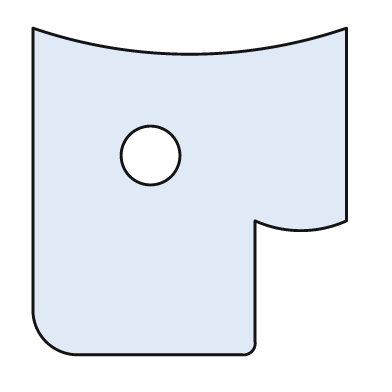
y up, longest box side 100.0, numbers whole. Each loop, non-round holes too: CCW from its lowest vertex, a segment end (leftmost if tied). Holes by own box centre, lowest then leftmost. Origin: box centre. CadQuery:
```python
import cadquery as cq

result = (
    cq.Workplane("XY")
    .moveTo(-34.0, -50.0)
    .lineTo(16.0, -50.0)
    .threePointArc((19.0, -49.0), (20.0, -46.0))
    .lineTo(20.0, -9.0)
    .threePointArc((34.0, -12.0), (48.0, -9.0))
    .lineTo(48.0, 50.0)
    .threePointArc((0.0, 42.0), (-48.0, 50.0))
    .lineTo(-48.0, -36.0)
    .threePointArc((-44.0, -46.0), (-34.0, -50.0))
    .close()
    .moveTo(-12.0, 11.0)
    .circle(9.0)
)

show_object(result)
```